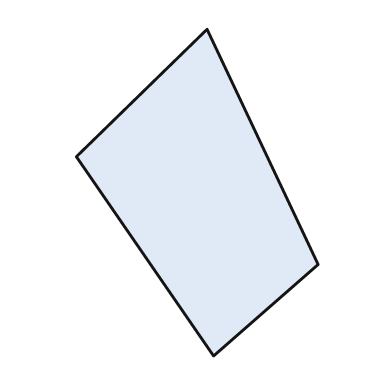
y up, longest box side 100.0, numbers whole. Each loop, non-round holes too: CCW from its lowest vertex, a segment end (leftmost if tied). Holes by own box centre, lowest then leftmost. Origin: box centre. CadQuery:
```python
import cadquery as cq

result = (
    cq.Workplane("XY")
    .moveTo(5.0, -50.0)
    .lineTo(37.0, -22.0)
    .lineTo(3.0, 50.0)
    .lineTo(-37.0, 11.0)
    .close()
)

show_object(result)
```